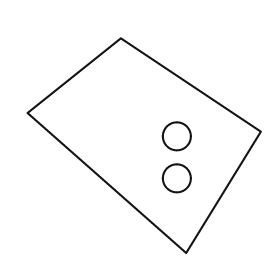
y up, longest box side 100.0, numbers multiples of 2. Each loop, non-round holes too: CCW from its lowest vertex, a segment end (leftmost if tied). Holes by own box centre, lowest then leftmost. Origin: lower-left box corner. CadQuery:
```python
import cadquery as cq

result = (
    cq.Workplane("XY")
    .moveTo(68.0, 0.0)
    .lineTo(100.0, 52.0)
    .lineTo(40.0, 92.0)
    .lineTo(0.0, 60.0)
    .close()
    .moveTo(64.0, 32.0)
    .circle(6.0)
    .moveTo(64.0, 50.0)
    .circle(6.0)
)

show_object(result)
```